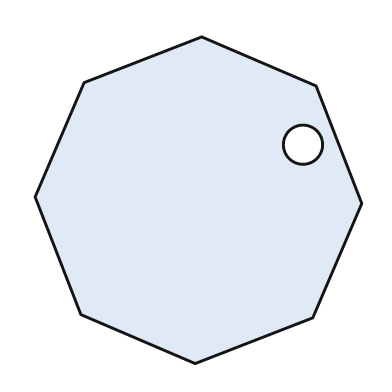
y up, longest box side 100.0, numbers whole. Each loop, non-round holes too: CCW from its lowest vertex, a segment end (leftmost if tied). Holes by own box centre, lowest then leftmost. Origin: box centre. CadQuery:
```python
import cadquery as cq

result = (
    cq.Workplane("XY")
    .moveTo(-1.0, -50.0)
    .lineTo(35.0, -36.0)
    .lineTo(50.0, -1.0)
    .lineTo(36.0, 35.0)
    .lineTo(1.0, 50.0)
    .lineTo(-35.0, 36.0)
    .lineTo(-50.0, 1.0)
    .lineTo(-36.0, -35.0)
    .close()
    .moveTo(32.0, 17.0)
    .circle(6.0)
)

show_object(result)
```